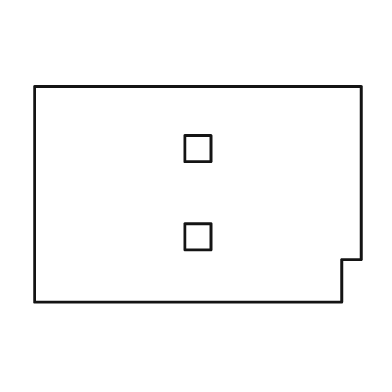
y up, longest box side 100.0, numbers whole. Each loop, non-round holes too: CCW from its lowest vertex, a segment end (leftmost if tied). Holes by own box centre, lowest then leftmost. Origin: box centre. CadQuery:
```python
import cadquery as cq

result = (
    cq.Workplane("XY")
    .moveTo(-50.0, -33.0)
    .lineTo(44.0, -33.0)
    .lineTo(44.0, -20.0)
    .lineTo(50.0, -20.0)
    .lineTo(50.0, 33.0)
    .lineTo(-50.0, 33.0)
    .close()
    .moveTo(-4.0, -17.0)
    .lineTo(4.0, -17.0)
    .lineTo(4.0, -9.0)
    .lineTo(-4.0, -9.0)
    .close()
    .moveTo(-4.0, 10.0)
    .lineTo(4.0, 10.0)
    .lineTo(4.0, 18.0)
    .lineTo(-4.0, 18.0)
    .close()
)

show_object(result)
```